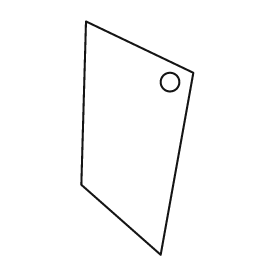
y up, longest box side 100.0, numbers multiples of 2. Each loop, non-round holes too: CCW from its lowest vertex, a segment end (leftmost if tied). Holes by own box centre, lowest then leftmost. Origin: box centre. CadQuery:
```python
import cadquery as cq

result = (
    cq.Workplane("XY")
    .moveTo(10.0, -50.0)
    .lineTo(24.0, 28.0)
    .lineTo(-22.0, 50.0)
    .lineTo(-24.0, -20.0)
    .close()
    .moveTo(14.0, 24.0)
    .circle(4.0)
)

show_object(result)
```